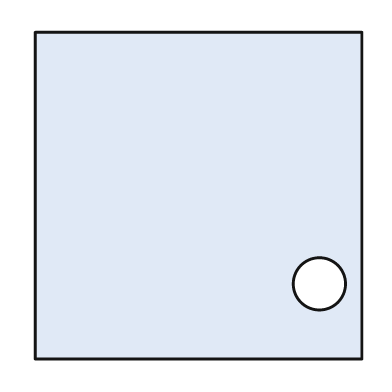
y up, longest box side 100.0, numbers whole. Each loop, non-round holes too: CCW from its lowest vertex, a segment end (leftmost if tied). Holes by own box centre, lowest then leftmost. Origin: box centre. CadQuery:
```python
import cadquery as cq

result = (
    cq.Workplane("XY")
    .moveTo(-50.0, -50.0)
    .lineTo(50.0, -50.0)
    .lineTo(50.0, 50.0)
    .lineTo(-50.0, 50.0)
    .close()
    .moveTo(37.0, -27.0)
    .circle(8.0)
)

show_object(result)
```